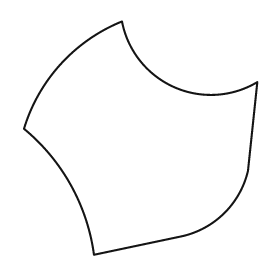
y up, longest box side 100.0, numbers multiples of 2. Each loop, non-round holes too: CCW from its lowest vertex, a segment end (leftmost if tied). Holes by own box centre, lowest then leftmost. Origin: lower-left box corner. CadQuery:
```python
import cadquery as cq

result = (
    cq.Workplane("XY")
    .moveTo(30.0, 0.0)
    .lineTo(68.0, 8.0)
    .threePointArc((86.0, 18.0), (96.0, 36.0))
    .lineTo(100.0, 74.0)
    .threePointArc((64.0, 72.0), (42.0, 100.0))
    .threePointArc((16.0, 82.0), (0.0, 54.0))
    .threePointArc((20.0, 30.0), (30.0, 0.0))
    .close()
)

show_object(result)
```